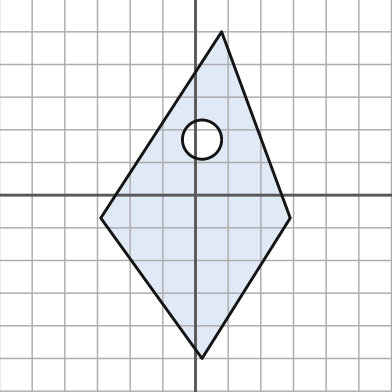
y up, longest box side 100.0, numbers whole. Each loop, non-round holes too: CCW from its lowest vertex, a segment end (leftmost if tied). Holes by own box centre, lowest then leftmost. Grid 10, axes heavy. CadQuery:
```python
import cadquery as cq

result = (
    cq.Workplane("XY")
    .moveTo(2.0, -50.0)
    .lineTo(29.0, -7.0)
    .lineTo(8.0, 50.0)
    .lineTo(-29.0, -7.0)
    .close()
    .moveTo(2.0, 17.0)
    .circle(6.0)
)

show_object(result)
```